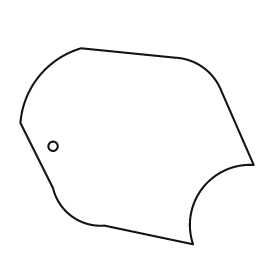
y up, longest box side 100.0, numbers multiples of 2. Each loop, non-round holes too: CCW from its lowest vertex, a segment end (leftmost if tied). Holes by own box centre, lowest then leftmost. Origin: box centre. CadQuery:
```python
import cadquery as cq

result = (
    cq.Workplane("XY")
    .moveTo(24.0, -42.0)
    .threePointArc((28.0, -18.0), (50.0, -8.0))
    .lineTo(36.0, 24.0)
    .threePointArc((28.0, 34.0), (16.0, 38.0))
    .lineTo(-24.0, 42.0)
    .threePointArc((-42.0, 30.0), (-50.0, 10.0))
    .lineTo(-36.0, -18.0)
    .threePointArc((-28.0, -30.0), (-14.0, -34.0))
    .close()
    .moveTo(-36.0, 0.0)
    .circle(2.0)
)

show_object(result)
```